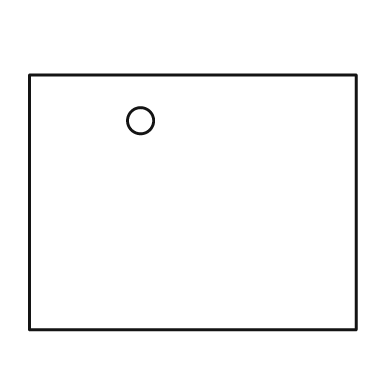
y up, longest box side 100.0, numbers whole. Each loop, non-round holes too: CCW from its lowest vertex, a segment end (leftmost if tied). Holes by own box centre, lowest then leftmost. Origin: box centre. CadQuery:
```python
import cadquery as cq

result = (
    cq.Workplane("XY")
    .moveTo(-50.0, -39.0)
    .lineTo(50.0, -39.0)
    .lineTo(50.0, 39.0)
    .lineTo(-50.0, 39.0)
    .close()
    .moveTo(-16.0, 25.0)
    .circle(4.0)
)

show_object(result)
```